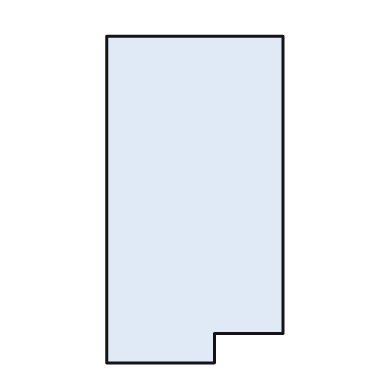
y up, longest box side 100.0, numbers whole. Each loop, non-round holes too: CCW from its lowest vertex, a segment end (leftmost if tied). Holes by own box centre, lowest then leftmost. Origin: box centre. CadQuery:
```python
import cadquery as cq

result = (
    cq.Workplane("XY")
    .moveTo(-27.0, -50.0)
    .lineTo(6.0, -50.0)
    .lineTo(6.0, -41.0)
    .lineTo(27.0, -41.0)
    .lineTo(27.0, 50.0)
    .lineTo(-27.0, 50.0)
    .close()
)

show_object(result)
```